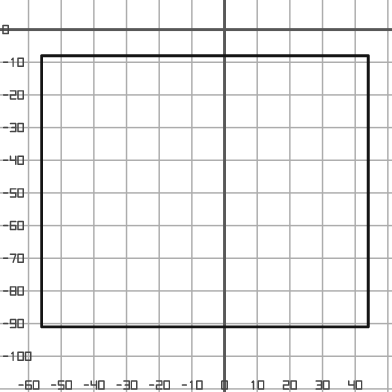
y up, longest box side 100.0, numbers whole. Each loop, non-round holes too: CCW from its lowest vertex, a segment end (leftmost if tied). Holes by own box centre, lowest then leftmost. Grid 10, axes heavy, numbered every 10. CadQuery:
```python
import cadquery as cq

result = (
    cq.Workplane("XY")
    .moveTo(-56.0, -91.0)
    .lineTo(44.0, -91.0)
    .lineTo(44.0, -8.0)
    .lineTo(-56.0, -8.0)
    .close()
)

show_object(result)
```